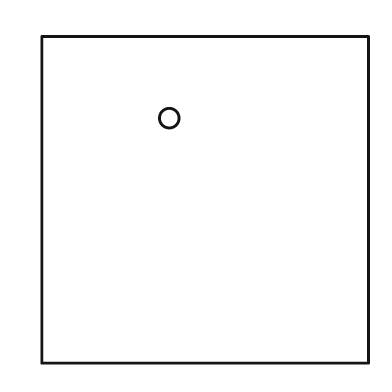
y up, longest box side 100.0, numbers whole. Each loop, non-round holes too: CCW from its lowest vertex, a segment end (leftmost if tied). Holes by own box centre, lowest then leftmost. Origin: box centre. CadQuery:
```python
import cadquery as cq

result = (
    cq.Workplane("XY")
    .moveTo(-50.0, -50.0)
    .lineTo(50.0, -50.0)
    .lineTo(50.0, 50.0)
    .lineTo(-50.0, 50.0)
    .close()
    .moveTo(-11.0, 25.0)
    .circle(3.0)
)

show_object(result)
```